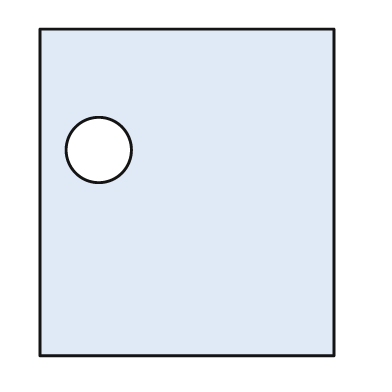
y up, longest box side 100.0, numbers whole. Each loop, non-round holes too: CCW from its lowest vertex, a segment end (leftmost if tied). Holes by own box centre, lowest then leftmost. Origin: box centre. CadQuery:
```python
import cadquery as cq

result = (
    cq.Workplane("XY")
    .moveTo(-45.0, -50.0)
    .lineTo(45.0, -50.0)
    .lineTo(45.0, 50.0)
    .lineTo(-45.0, 50.0)
    .close()
    .moveTo(-27.0, 13.0)
    .circle(10.0)
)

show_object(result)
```